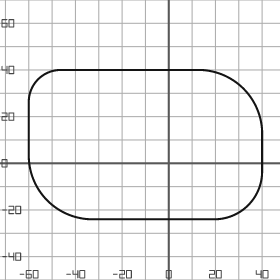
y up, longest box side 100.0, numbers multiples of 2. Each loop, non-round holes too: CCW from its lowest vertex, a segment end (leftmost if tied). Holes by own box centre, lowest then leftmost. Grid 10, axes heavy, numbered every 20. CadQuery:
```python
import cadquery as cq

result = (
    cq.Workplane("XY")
    .moveTo(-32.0, -24.0)
    .lineTo(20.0, -24.0)
    .threePointArc((34.0, -18.0), (40.0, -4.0))
    .lineTo(40.0, 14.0)
    .threePointArc((32.0, 32.0), (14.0, 40.0))
    .lineTo(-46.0, 40.0)
    .threePointArc((-56.0, 36.0), (-60.0, 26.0))
    .lineTo(-60.0, 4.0)
    .threePointArc((-52.0, -16.0), (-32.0, -24.0))
    .close()
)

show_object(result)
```